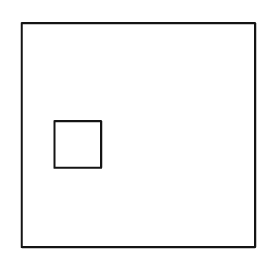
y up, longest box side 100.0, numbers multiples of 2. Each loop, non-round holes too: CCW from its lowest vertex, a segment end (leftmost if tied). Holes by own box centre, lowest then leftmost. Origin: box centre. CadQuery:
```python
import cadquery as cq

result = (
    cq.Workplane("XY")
    .moveTo(-50.0, -48.0)
    .lineTo(50.0, -48.0)
    .lineTo(50.0, 48.0)
    .lineTo(-50.0, 48.0)
    .close()
    .moveTo(-36.0, -14.0)
    .lineTo(-16.0, -14.0)
    .lineTo(-16.0, 6.0)
    .lineTo(-36.0, 6.0)
    .close()
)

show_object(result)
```